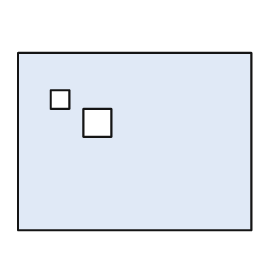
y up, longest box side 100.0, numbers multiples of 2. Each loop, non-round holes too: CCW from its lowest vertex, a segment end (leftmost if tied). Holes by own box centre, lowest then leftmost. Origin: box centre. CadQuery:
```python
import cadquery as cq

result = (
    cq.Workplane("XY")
    .moveTo(-50.0, -38.0)
    .lineTo(50.0, -38.0)
    .lineTo(50.0, 38.0)
    .lineTo(-50.0, 38.0)
    .close()
    .moveTo(-22.0, 2.0)
    .lineTo(-10.0, 2.0)
    .lineTo(-10.0, 14.0)
    .lineTo(-22.0, 14.0)
    .close()
    .moveTo(-36.0, 14.0)
    .lineTo(-28.0, 14.0)
    .lineTo(-28.0, 22.0)
    .lineTo(-36.0, 22.0)
    .close()
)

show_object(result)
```